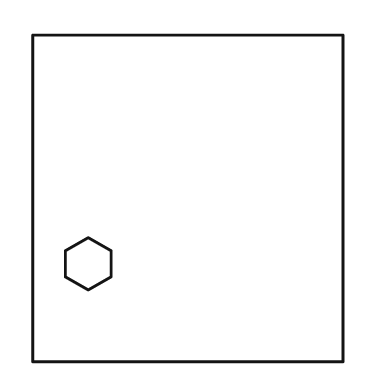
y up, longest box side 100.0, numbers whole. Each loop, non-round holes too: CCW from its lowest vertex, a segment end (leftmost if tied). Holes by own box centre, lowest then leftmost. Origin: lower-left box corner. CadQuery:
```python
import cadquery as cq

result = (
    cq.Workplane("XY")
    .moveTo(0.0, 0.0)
    .lineTo(95.0, 0.0)
    .lineTo(95.0, 100.0)
    .lineTo(0.0, 100.0)
    .close()
    .moveTo(17.0, 22.0)
    .lineTo(24.0, 26.0)
    .lineTo(24.0, 34.0)
    .lineTo(17.0, 38.0)
    .lineTo(10.0, 34.0)
    .lineTo(10.0, 26.0)
    .close()
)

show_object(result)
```